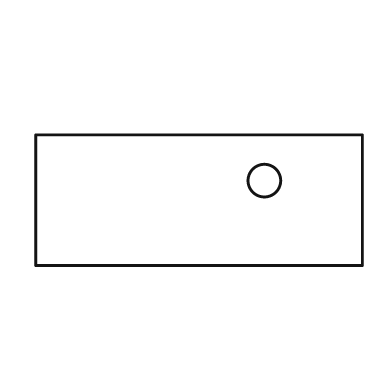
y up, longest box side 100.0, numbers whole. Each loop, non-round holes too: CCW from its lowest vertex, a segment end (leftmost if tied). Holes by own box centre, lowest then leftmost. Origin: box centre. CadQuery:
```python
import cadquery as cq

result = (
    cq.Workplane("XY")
    .moveTo(-50.0, -20.0)
    .lineTo(50.0, -20.0)
    .lineTo(50.0, 20.0)
    .lineTo(-50.0, 20.0)
    .close()
    .moveTo(20.0, 6.0)
    .circle(5.0)
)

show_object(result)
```